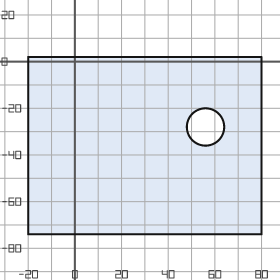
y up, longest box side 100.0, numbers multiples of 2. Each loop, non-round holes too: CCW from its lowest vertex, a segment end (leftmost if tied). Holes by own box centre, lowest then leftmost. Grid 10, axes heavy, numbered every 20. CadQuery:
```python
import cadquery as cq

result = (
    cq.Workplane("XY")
    .moveTo(-20.0, -74.0)
    .lineTo(80.0, -74.0)
    .lineTo(80.0, 2.0)
    .lineTo(-20.0, 2.0)
    .close()
    .moveTo(56.0, -28.0)
    .circle(8.0)
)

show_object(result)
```